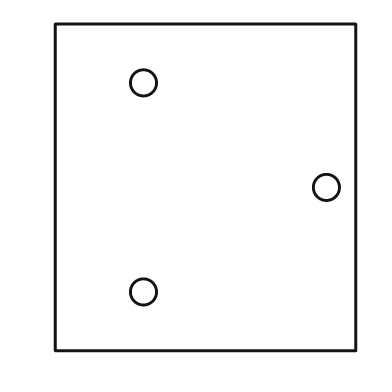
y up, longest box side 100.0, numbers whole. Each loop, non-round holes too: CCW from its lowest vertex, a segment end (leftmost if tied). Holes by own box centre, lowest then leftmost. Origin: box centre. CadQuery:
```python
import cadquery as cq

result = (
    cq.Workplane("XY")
    .moveTo(-46.0, -50.0)
    .lineTo(46.0, -50.0)
    .lineTo(46.0, 50.0)
    .lineTo(-46.0, 50.0)
    .close()
    .moveTo(-19.0, -32.0)
    .circle(4.0)
    .moveTo(37.0, 0.0)
    .circle(4.0)
    .moveTo(-19.0, 32.0)
    .circle(4.0)
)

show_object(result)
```